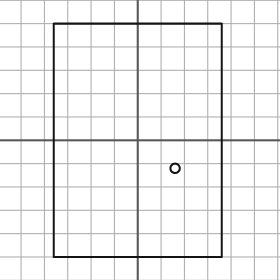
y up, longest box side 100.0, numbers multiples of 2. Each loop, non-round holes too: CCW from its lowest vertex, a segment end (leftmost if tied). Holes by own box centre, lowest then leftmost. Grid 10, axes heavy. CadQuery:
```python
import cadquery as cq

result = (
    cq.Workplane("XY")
    .moveTo(-36.0, -50.0)
    .lineTo(36.0, -50.0)
    .lineTo(36.0, 50.0)
    .lineTo(-36.0, 50.0)
    .close()
    .moveTo(16.0, -12.0)
    .circle(2.0)
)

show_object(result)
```